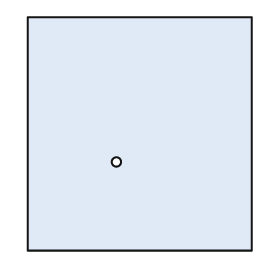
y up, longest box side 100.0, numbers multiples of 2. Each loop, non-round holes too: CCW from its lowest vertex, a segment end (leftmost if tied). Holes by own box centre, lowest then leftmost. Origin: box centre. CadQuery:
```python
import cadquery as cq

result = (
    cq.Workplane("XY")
    .moveTo(-48.0, -50.0)
    .lineTo(48.0, -50.0)
    .lineTo(48.0, 50.0)
    .lineTo(-48.0, 50.0)
    .close()
    .moveTo(-10.0, -12.0)
    .circle(2.0)
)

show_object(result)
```